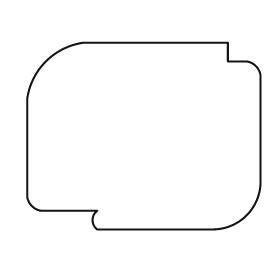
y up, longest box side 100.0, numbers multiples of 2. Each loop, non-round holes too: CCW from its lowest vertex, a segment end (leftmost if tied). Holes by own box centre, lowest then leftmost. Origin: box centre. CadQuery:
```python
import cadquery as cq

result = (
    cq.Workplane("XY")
    .moveTo(-20.0, -40.0)
    .lineTo(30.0, -40.0)
    .threePointArc((44.0, -34.0), (50.0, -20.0))
    .lineTo(50.0, 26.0)
    .threePointArc((48.0, 30.0), (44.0, 32.0))
    .lineTo(36.0, 32.0)
    .lineTo(36.0, 40.0)
    .lineTo(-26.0, 40.0)
    .threePointArc((-42.0, 32.0), (-50.0, 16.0))
    .lineTo(-50.0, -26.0)
    .threePointArc((-48.0, -30.0), (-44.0, -32.0))
    .lineTo(-20.0, -32.0)
    .threePointArc((-22.0, -36.0), (-20.0, -40.0))
    .close()
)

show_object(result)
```